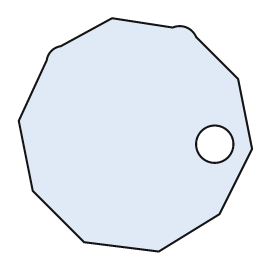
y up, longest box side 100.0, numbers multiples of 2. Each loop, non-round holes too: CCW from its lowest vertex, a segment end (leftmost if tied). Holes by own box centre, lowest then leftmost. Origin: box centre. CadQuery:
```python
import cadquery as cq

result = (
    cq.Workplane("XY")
    .moveTo(10.0, -50.0)
    .lineTo(36.0, -34.0)
    .lineTo(50.0, -6.0)
    .lineTo(44.0, 24.0)
    .lineTo(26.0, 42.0)
    .threePointArc((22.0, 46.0), (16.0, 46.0))
    .lineTo(-10.0, 50.0)
    .lineTo(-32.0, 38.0)
    .threePointArc((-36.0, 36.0), (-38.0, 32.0))
    .lineTo(-50.0, 6.0)
    .lineTo(-44.0, -24.0)
    .lineTo(-22.0, -46.0)
    .close()
    .moveTo(34.0, -4.0)
    .circle(8.0)
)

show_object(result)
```